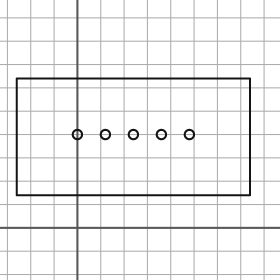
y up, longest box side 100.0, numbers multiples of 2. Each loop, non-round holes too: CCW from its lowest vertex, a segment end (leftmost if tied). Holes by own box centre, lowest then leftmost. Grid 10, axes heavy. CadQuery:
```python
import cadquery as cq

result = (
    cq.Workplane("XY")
    .moveTo(-26.0, 14.0)
    .lineTo(74.0, 14.0)
    .lineTo(74.0, 64.0)
    .lineTo(-26.0, 64.0)
    .close()
    .moveTo(0.0, 40.0)
    .circle(2.0)
    .moveTo(12.0, 40.0)
    .circle(2.0)
    .moveTo(24.0, 40.0)
    .circle(2.0)
    .moveTo(36.0, 40.0)
    .circle(2.0)
    .moveTo(48.0, 40.0)
    .circle(2.0)
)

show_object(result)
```